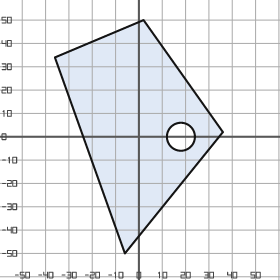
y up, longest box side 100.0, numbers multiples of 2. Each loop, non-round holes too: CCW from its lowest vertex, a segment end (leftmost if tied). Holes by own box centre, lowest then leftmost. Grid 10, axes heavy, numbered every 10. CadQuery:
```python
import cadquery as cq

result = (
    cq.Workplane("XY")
    .moveTo(-6.0, -50.0)
    .lineTo(36.0, 2.0)
    .lineTo(2.0, 50.0)
    .lineTo(-36.0, 34.0)
    .close()
    .moveTo(18.0, 0.0)
    .circle(6.0)
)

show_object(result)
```